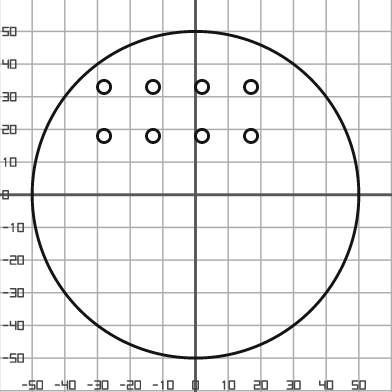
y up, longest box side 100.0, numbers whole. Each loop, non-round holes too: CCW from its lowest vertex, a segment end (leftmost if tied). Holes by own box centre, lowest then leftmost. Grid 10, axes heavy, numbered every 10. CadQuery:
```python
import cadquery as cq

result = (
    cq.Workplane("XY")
    .moveTo(0.0, 0.0)
    .circle(50.0)
    .moveTo(-28.0, 18.0)
    .circle(2.0)
    .moveTo(-13.0, 18.0)
    .circle(2.0)
    .moveTo(2.0, 18.0)
    .circle(2.0)
    .moveTo(17.0, 18.0)
    .circle(2.0)
    .moveTo(-28.0, 33.0)
    .circle(2.0)
    .moveTo(-13.0, 33.0)
    .circle(2.0)
    .moveTo(2.0, 33.0)
    .circle(2.0)
    .moveTo(17.0, 33.0)
    .circle(2.0)
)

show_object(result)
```